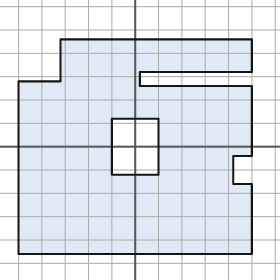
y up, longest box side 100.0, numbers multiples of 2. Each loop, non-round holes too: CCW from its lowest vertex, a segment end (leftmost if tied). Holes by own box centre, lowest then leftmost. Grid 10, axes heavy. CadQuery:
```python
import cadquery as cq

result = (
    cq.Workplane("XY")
    .moveTo(-50.0, -46.0)
    .lineTo(50.0, -46.0)
    .lineTo(50.0, -16.0)
    .lineTo(42.0, -16.0)
    .lineTo(42.0, -4.0)
    .lineTo(50.0, -4.0)
    .lineTo(50.0, 26.0)
    .lineTo(2.0, 26.0)
    .lineTo(2.0, 32.0)
    .lineTo(50.0, 32.0)
    .lineTo(50.0, 46.0)
    .lineTo(-32.0, 46.0)
    .lineTo(-32.0, 28.0)
    .lineTo(-50.0, 28.0)
    .close()
    .moveTo(-10.0, -12.0)
    .lineTo(10.0, -12.0)
    .lineTo(10.0, 12.0)
    .lineTo(-10.0, 12.0)
    .close()
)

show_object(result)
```